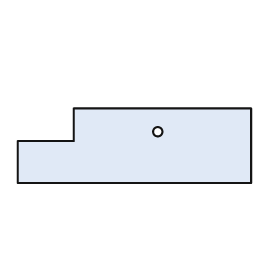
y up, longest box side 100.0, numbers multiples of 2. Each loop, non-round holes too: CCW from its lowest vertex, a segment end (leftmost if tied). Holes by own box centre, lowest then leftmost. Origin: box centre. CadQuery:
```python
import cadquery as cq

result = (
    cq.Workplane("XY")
    .moveTo(-50.0, -16.0)
    .lineTo(50.0, -16.0)
    .lineTo(50.0, 16.0)
    .lineTo(-26.0, 16.0)
    .lineTo(-26.0, 2.0)
    .lineTo(-50.0, 2.0)
    .close()
    .moveTo(10.0, 6.0)
    .circle(2.0)
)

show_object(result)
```